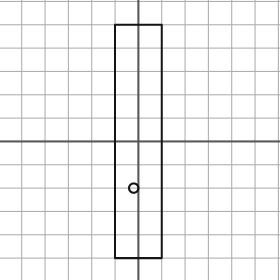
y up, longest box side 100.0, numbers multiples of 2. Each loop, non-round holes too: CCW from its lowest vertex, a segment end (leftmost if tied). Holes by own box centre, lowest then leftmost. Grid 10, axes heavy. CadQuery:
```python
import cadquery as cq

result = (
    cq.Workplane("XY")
    .moveTo(-10.0, -50.0)
    .lineTo(10.0, -50.0)
    .lineTo(10.0, 50.0)
    .lineTo(-10.0, 50.0)
    .close()
    .moveTo(-2.0, -20.0)
    .circle(2.0)
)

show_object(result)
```